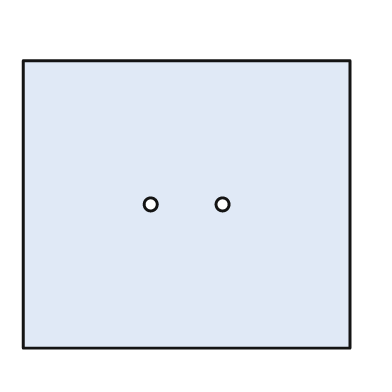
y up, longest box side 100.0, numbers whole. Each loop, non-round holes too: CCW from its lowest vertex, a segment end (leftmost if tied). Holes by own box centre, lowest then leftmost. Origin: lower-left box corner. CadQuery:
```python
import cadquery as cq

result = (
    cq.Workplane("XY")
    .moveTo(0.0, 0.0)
    .lineTo(100.0, 0.0)
    .lineTo(100.0, 88.0)
    .lineTo(0.0, 88.0)
    .close()
    .moveTo(39.0, 44.0)
    .circle(2.0)
    .moveTo(61.0, 44.0)
    .circle(2.0)
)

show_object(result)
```